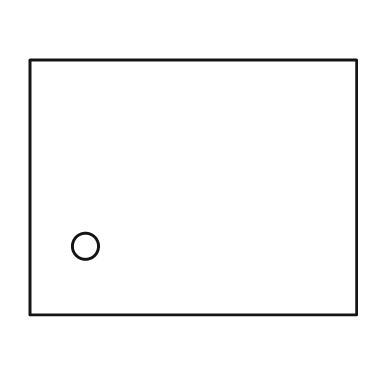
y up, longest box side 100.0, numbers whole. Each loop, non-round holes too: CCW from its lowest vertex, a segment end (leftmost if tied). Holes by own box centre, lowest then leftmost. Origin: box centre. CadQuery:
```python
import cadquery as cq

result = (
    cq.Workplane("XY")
    .moveTo(-50.0, -39.0)
    .lineTo(50.0, -39.0)
    .lineTo(50.0, 39.0)
    .lineTo(-50.0, 39.0)
    .close()
    .moveTo(-33.0, -18.0)
    .circle(4.0)
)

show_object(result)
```